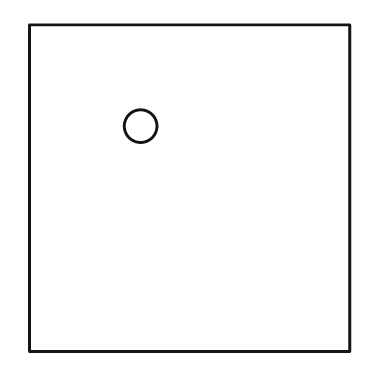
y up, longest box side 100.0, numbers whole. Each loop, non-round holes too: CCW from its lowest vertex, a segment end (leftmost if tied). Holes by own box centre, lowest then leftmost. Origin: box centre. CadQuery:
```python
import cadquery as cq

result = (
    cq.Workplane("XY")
    .moveTo(-49.0, -50.0)
    .lineTo(49.0, -50.0)
    .lineTo(49.0, 50.0)
    .lineTo(-49.0, 50.0)
    .close()
    .moveTo(-15.0, 19.0)
    .circle(5.0)
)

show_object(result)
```